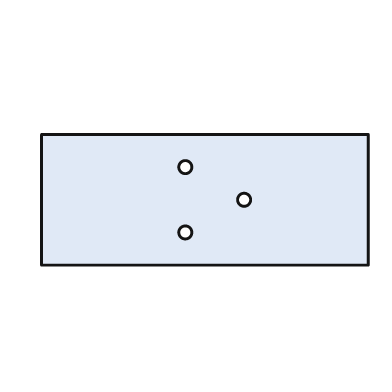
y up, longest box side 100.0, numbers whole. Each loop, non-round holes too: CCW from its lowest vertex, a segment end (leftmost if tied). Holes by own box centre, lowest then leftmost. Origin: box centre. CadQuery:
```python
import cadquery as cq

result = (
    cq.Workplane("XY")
    .moveTo(-50.0, -20.0)
    .lineTo(50.0, -20.0)
    .lineTo(50.0, 20.0)
    .lineTo(-50.0, 20.0)
    .close()
    .moveTo(-6.0, -10.0)
    .circle(2.0)
    .moveTo(12.0, 0.0)
    .circle(2.0)
    .moveTo(-6.0, 10.0)
    .circle(2.0)
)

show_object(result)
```